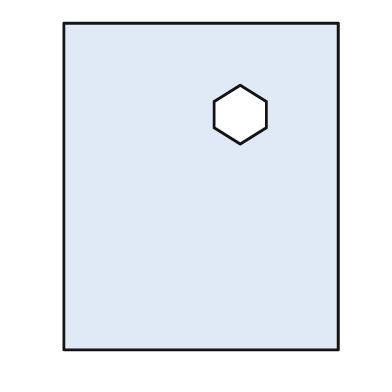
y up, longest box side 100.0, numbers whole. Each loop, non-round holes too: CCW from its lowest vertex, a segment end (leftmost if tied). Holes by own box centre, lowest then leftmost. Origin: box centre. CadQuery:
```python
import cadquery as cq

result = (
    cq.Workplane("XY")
    .moveTo(-42.0, -50.0)
    .lineTo(42.0, -50.0)
    .lineTo(42.0, 50.0)
    .lineTo(-42.0, 50.0)
    .close()
    .moveTo(12.0, 13.0)
    .lineTo(20.0, 18.0)
    .lineTo(20.0, 26.0)
    .lineTo(12.0, 31.0)
    .lineTo(4.0, 26.0)
    .lineTo(4.0, 18.0)
    .close()
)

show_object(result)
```